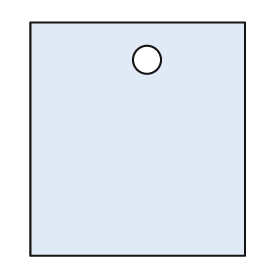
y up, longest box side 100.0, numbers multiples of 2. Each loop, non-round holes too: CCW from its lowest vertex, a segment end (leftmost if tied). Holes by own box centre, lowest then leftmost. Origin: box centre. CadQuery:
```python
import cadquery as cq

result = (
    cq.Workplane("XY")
    .moveTo(-46.0, -50.0)
    .lineTo(46.0, -50.0)
    .lineTo(46.0, 50.0)
    .lineTo(-46.0, 50.0)
    .close()
    .moveTo(4.0, 34.0)
    .circle(6.0)
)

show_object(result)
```